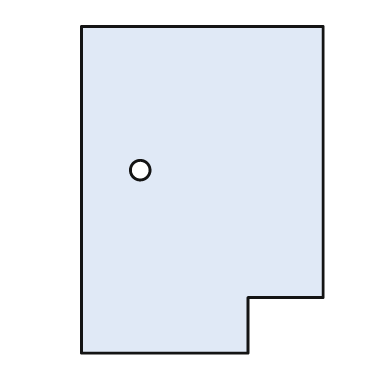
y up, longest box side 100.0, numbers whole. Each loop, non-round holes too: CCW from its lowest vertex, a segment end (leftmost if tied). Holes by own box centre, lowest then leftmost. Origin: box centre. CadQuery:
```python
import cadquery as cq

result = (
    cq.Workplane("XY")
    .moveTo(-37.0, -50.0)
    .lineTo(14.0, -50.0)
    .lineTo(14.0, -33.0)
    .lineTo(37.0, -33.0)
    .lineTo(37.0, 50.0)
    .lineTo(-37.0, 50.0)
    .close()
    .moveTo(-19.0, 6.0)
    .circle(3.0)
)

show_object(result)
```